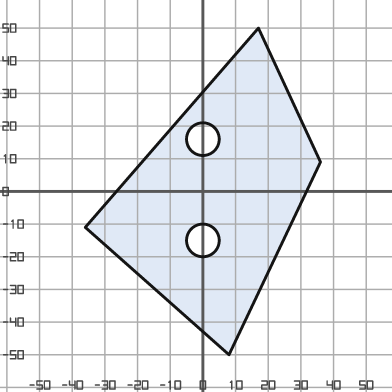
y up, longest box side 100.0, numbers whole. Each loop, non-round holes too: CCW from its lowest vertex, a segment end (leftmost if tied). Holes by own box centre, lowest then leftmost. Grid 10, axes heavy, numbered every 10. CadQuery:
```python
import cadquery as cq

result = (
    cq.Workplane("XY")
    .moveTo(8.0, -50.0)
    .lineTo(36.0, 9.0)
    .lineTo(17.0, 50.0)
    .lineTo(-36.0, -11.0)
    .close()
    .moveTo(0.0, -15.0)
    .circle(5.0)
    .moveTo(0.0, 16.0)
    .circle(5.0)
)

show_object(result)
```